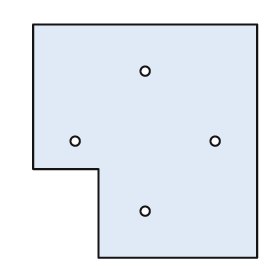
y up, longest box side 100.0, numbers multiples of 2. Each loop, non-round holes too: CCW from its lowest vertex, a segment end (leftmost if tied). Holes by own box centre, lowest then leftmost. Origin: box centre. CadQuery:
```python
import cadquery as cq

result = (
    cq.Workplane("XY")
    .moveTo(-20.0, -50.0)
    .lineTo(48.0, -50.0)
    .lineTo(48.0, 50.0)
    .lineTo(-48.0, 50.0)
    .lineTo(-48.0, -12.0)
    .lineTo(-20.0, -12.0)
    .close()
    .moveTo(0.0, -30.0)
    .circle(2.0)
    .moveTo(-30.0, 0.0)
    .circle(2.0)
    .moveTo(30.0, 0.0)
    .circle(2.0)
    .moveTo(0.0, 30.0)
    .circle(2.0)
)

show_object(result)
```